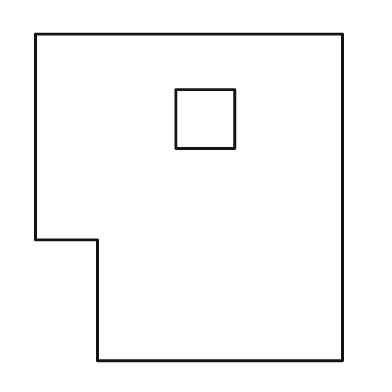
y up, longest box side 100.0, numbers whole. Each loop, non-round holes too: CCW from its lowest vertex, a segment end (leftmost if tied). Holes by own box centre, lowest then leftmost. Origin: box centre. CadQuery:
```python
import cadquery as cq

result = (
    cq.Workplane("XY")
    .moveTo(-28.0, -50.0)
    .lineTo(47.0, -50.0)
    .lineTo(47.0, 50.0)
    .lineTo(-47.0, 50.0)
    .lineTo(-47.0, -13.0)
    .lineTo(-28.0, -13.0)
    .close()
    .moveTo(-4.0, 15.0)
    .lineTo(14.0, 15.0)
    .lineTo(14.0, 33.0)
    .lineTo(-4.0, 33.0)
    .close()
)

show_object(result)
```